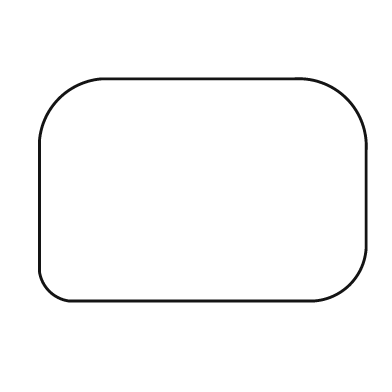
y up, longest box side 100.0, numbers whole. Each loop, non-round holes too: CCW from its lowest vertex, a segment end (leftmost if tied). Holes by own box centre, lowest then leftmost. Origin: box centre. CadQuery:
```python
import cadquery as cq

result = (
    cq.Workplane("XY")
    .moveTo(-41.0, -34.0)
    .lineTo(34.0, -34.0)
    .threePointArc((45.0, -29.0), (50.0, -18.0))
    .lineTo(50.0, 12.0)
    .threePointArc((44.0, 28.0), (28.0, 34.0))
    .lineTo(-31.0, 34.0)
    .threePointArc((-44.0, 28.0), (-50.0, 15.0))
    .lineTo(-50.0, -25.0)
    .threePointArc((-47.0, -31.0), (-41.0, -34.0))
    .close()
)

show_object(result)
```